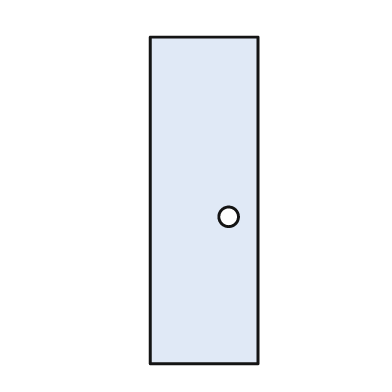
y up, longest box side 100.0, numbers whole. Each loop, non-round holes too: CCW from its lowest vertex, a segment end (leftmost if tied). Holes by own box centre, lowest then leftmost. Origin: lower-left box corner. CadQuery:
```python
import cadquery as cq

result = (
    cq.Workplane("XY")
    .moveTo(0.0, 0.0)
    .lineTo(33.0, 0.0)
    .lineTo(33.0, 100.0)
    .lineTo(0.0, 100.0)
    .close()
    .moveTo(24.0, 45.0)
    .circle(3.0)
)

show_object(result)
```